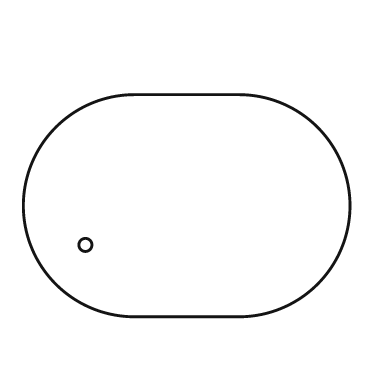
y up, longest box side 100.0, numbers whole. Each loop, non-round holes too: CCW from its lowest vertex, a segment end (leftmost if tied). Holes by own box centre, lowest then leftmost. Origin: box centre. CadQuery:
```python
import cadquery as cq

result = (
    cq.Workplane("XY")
    .moveTo(-16.0, -34.0)
    .lineTo(16.0, -34.0)
    .threePointArc((50.0, 0.0), (16.0, 34.0))
    .lineTo(-16.0, 34.0)
    .threePointArc((-50.0, 0.0), (-16.0, -34.0))
    .close()
    .moveTo(-31.0, -12.0)
    .circle(2.0)
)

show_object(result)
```